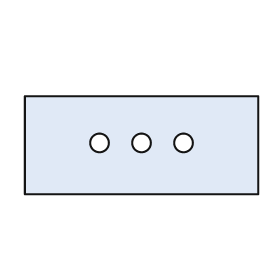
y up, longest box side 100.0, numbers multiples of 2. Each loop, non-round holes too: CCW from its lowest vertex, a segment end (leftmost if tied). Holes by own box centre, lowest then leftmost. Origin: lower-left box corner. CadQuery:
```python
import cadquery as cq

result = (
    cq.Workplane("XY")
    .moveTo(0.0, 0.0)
    .lineTo(100.0, 0.0)
    .lineTo(100.0, 42.0)
    .lineTo(0.0, 42.0)
    .close()
    .moveTo(32.0, 22.0)
    .circle(4.0)
    .moveTo(50.0, 22.0)
    .circle(4.0)
    .moveTo(68.0, 22.0)
    .circle(4.0)
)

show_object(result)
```